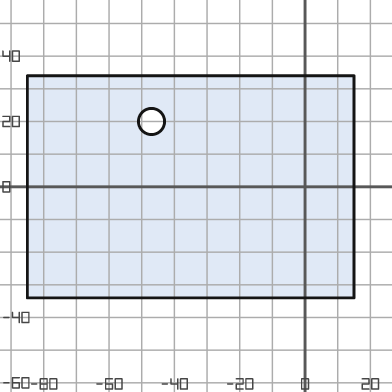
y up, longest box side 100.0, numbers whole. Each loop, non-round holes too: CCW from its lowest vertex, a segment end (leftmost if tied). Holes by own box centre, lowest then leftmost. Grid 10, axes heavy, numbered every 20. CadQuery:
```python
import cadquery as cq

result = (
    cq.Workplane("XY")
    .moveTo(-85.0, -34.0)
    .lineTo(15.0, -34.0)
    .lineTo(15.0, 34.0)
    .lineTo(-85.0, 34.0)
    .close()
    .moveTo(-47.0, 20.0)
    .circle(4.0)
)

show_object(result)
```